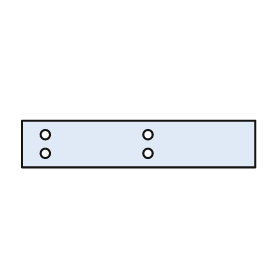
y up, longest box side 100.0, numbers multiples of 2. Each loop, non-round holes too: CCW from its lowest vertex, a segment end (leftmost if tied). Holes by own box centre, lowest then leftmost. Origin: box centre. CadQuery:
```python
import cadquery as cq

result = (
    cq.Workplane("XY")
    .moveTo(-50.0, -10.0)
    .lineTo(50.0, -10.0)
    .lineTo(50.0, 10.0)
    .lineTo(-50.0, 10.0)
    .close()
    .moveTo(-40.0, -4.0)
    .circle(2.0)
    .moveTo(4.0, -4.0)
    .circle(2.0)
    .moveTo(-40.0, 4.0)
    .circle(2.0)
    .moveTo(4.0, 4.0)
    .circle(2.0)
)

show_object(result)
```